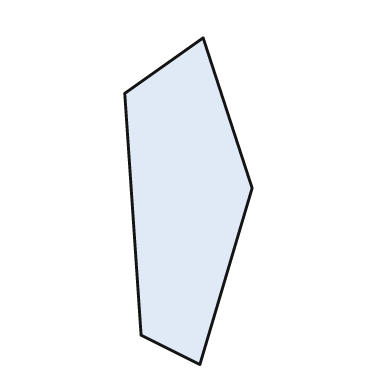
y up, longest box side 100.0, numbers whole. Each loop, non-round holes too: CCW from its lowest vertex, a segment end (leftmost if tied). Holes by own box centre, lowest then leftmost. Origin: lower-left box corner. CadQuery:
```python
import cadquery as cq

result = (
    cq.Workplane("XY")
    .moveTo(23.0, 0.0)
    .lineTo(39.0, 54.0)
    .lineTo(24.0, 100.0)
    .lineTo(0.0, 83.0)
    .lineTo(5.0, 9.0)
    .close()
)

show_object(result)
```